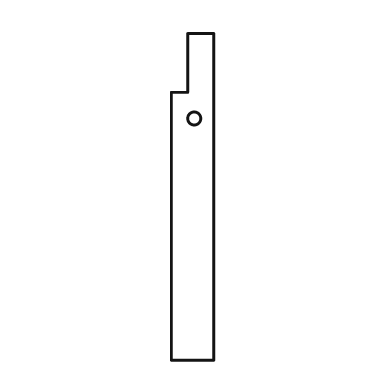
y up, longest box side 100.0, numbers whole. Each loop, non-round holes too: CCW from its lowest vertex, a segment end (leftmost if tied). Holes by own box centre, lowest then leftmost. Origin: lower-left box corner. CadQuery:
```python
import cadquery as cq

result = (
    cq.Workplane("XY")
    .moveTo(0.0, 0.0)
    .lineTo(13.0, 0.0)
    .lineTo(13.0, 100.0)
    .lineTo(5.0, 100.0)
    .lineTo(5.0, 82.0)
    .lineTo(0.0, 82.0)
    .close()
    .moveTo(7.0, 74.0)
    .circle(2.0)
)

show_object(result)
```